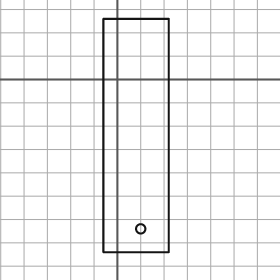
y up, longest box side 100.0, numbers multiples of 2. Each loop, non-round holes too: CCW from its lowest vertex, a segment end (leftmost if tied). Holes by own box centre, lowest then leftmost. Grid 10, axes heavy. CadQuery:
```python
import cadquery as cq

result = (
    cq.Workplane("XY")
    .moveTo(-6.0, -74.0)
    .lineTo(22.0, -74.0)
    .lineTo(22.0, 26.0)
    .lineTo(-6.0, 26.0)
    .close()
    .moveTo(10.0, -64.0)
    .circle(2.0)
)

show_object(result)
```